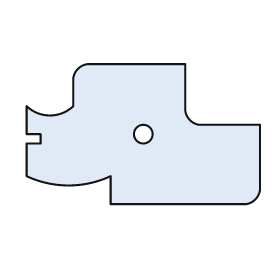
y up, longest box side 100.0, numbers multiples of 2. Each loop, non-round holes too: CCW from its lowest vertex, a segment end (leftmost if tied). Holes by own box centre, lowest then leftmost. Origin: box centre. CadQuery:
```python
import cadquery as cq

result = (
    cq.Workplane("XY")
    .moveTo(-14.0, -30.0)
    .lineTo(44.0, -30.0)
    .threePointArc((48.0, -28.0), (50.0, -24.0))
    .lineTo(50.0, 4.0)
    .lineTo(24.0, 4.0)
    .threePointArc((20.0, 6.0), (18.0, 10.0))
    .lineTo(18.0, 30.0)
    .lineTo(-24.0, 30.0)
    .threePointArc((-28.0, 28.0), (-30.0, 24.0))
    .lineTo(-30.0, 12.0)
    .threePointArc((-40.0, 8.0), (-50.0, 12.0))
    .lineTo(-50.0, 0.0)
    .lineTo(-44.0, 0.0)
    .lineTo(-44.0, -4.0)
    .lineTo(-50.0, -4.0)
    .lineTo(-50.0, -18.0)
    .threePointArc((-32.0, -22.0), (-14.0, -18.0))
    .close()
    .moveTo(0.0, 0.0)
    .circle(4.0)
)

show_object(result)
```